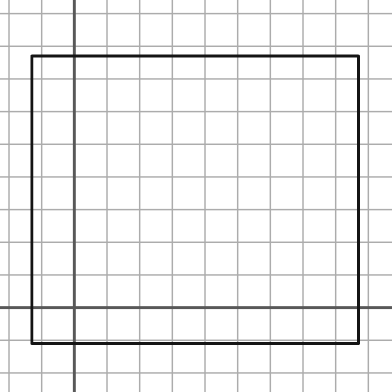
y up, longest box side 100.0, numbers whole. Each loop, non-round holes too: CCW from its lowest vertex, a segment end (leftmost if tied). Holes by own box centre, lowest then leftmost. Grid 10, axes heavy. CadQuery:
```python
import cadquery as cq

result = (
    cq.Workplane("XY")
    .moveTo(-13.0, -11.0)
    .lineTo(87.0, -11.0)
    .lineTo(87.0, 77.0)
    .lineTo(-13.0, 77.0)
    .close()
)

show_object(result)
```